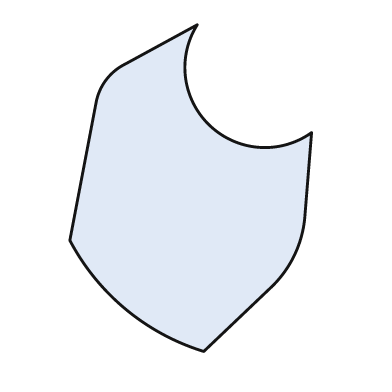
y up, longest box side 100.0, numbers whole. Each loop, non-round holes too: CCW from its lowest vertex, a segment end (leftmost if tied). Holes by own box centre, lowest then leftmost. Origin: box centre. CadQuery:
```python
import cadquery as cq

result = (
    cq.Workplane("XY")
    .moveTo(4.0, -50.0)
    .lineTo(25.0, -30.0)
    .threePointArc((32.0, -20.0), (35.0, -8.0))
    .lineTo(37.0, 17.0)
    .threePointArc((6.0, 19.0), (2.0, 50.0))
    .lineTo(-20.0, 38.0)
    .threePointArc((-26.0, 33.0), (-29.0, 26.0))
    .lineTo(-37.0, -16.0)
    .threePointArc((-20.0, -37.0), (4.0, -50.0))
    .close()
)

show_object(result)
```